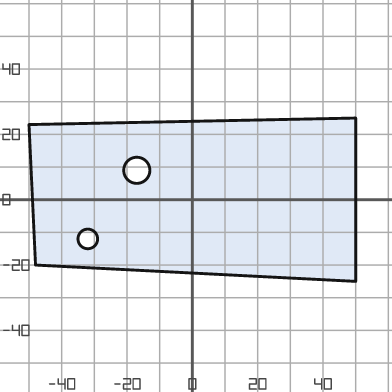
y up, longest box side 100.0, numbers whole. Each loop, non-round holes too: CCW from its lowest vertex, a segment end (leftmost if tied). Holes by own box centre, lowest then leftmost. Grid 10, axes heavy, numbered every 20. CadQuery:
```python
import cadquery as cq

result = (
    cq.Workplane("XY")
    .moveTo(50.0, -25.0)
    .lineTo(50.0, 25.0)
    .lineTo(-50.0, 23.0)
    .lineTo(-48.0, -20.0)
    .close()
    .moveTo(-32.0, -12.0)
    .circle(3.0)
    .moveTo(-17.0, 9.0)
    .circle(4.0)
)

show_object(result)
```